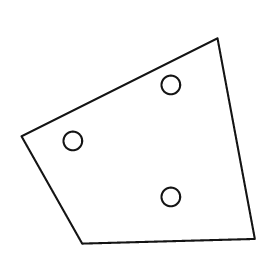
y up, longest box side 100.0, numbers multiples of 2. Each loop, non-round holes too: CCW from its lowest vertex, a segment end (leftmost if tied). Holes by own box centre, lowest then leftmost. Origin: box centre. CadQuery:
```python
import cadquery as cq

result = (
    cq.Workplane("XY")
    .moveTo(-24.0, -44.0)
    .lineTo(50.0, -42.0)
    .lineTo(34.0, 44.0)
    .lineTo(-50.0, 2.0)
    .close()
    .moveTo(14.0, -24.0)
    .circle(4.0)
    .moveTo(-28.0, 0.0)
    .circle(4.0)
    .moveTo(14.0, 24.0)
    .circle(4.0)
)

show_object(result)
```